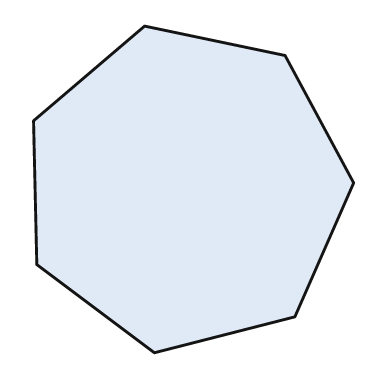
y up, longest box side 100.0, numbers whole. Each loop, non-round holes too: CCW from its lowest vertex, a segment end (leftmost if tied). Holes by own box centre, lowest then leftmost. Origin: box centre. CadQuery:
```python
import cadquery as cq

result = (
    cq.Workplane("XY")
    .moveTo(-12.0, -50.0)
    .lineTo(31.0, -39.0)
    .lineTo(49.0, 2.0)
    .lineTo(28.0, 41.0)
    .lineTo(-15.0, 50.0)
    .lineTo(-49.0, 21.0)
    .lineTo(-48.0, -23.0)
    .close()
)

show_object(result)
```